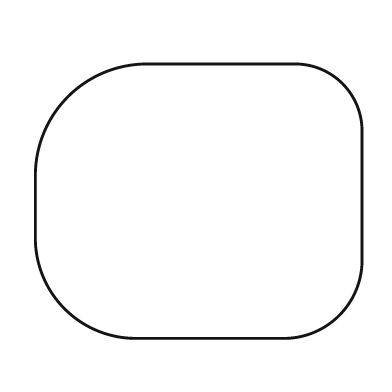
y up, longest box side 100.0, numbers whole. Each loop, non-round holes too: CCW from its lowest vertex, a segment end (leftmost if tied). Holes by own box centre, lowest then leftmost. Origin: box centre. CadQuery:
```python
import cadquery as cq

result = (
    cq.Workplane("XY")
    .moveTo(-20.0, -42.0)
    .lineTo(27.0, -42.0)
    .threePointArc((43.0, -35.0), (50.0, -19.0))
    .lineTo(50.0, 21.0)
    .threePointArc((44.0, 36.0), (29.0, 42.0))
    .lineTo(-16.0, 42.0)
    .threePointArc((-40.0, 32.0), (-50.0, 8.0))
    .lineTo(-50.0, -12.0)
    .threePointArc((-41.0, -33.0), (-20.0, -42.0))
    .close()
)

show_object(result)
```